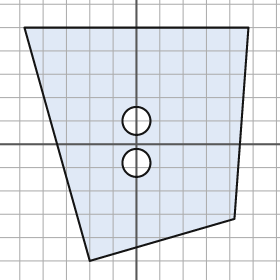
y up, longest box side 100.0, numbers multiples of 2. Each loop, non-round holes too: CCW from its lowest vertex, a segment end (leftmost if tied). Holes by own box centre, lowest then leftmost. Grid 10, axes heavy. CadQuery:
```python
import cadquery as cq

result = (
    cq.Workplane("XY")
    .moveTo(-20.0, -50.0)
    .lineTo(42.0, -32.0)
    .lineTo(48.0, 50.0)
    .lineTo(-48.0, 50.0)
    .close()
    .moveTo(0.0, -8.0)
    .circle(6.0)
    .moveTo(0.0, 10.0)
    .circle(6.0)
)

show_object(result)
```